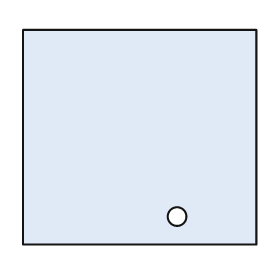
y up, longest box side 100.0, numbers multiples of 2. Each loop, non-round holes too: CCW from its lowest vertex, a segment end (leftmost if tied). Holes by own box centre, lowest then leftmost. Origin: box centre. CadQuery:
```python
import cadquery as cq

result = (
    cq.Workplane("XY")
    .moveTo(-50.0, -46.0)
    .lineTo(50.0, -46.0)
    .lineTo(50.0, 46.0)
    .lineTo(-50.0, 46.0)
    .close()
    .moveTo(16.0, -34.0)
    .circle(4.0)
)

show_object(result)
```